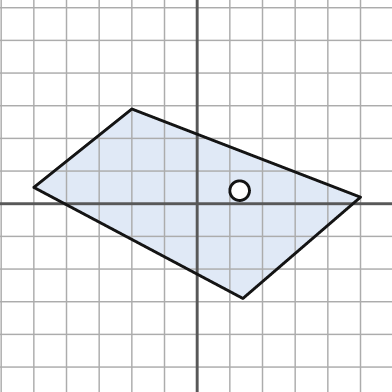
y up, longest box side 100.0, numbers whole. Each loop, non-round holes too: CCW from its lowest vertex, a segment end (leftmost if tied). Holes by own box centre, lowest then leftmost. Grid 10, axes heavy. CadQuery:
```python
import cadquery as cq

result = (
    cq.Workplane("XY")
    .moveTo(14.0, -29.0)
    .lineTo(50.0, 2.0)
    .lineTo(-20.0, 29.0)
    .lineTo(-50.0, 5.0)
    .close()
    .moveTo(13.0, 4.0)
    .circle(3.0)
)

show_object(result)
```